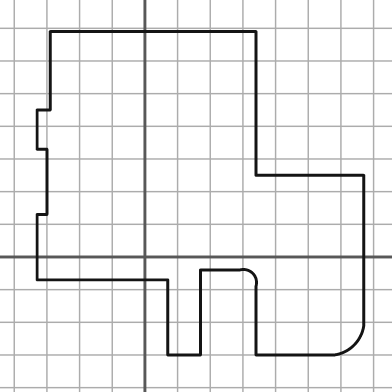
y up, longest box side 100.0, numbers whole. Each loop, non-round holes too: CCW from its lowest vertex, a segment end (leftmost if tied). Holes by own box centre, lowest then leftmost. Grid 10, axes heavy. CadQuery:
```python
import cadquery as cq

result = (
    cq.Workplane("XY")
    .moveTo(7.0, -30.0)
    .lineTo(17.0, -30.0)
    .lineTo(17.0, -4.0)
    .lineTo(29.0, -4.0)
    .threePointArc((33.0, -5.0), (34.0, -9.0))
    .lineTo(34.0, -30.0)
    .lineTo(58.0, -30.0)
    .threePointArc((64.0, -27.0), (67.0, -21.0))
    .lineTo(67.0, 25.0)
    .lineTo(34.0, 25.0)
    .lineTo(34.0, 69.0)
    .lineTo(-29.0, 69.0)
    .lineTo(-29.0, 45.0)
    .lineTo(-33.0, 45.0)
    .lineTo(-33.0, 33.0)
    .lineTo(-30.0, 33.0)
    .lineTo(-30.0, 13.0)
    .lineTo(-33.0, 13.0)
    .lineTo(-33.0, -7.0)
    .lineTo(7.0, -7.0)
    .close()
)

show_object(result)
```